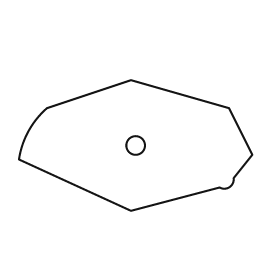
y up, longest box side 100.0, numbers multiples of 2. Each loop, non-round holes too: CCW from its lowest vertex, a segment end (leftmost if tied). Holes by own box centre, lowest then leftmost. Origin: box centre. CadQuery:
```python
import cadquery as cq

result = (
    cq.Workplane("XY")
    .moveTo(-2.0, -28.0)
    .lineTo(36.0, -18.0)
    .threePointArc((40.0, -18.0), (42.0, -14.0))
    .lineTo(50.0, -4.0)
    .lineTo(40.0, 16.0)
    .lineTo(-2.0, 28.0)
    .lineTo(-38.0, 16.0)
    .threePointArc((-46.0, 6.0), (-50.0, -6.0))
    .close()
    .moveTo(0.0, 0.0)
    .circle(4.0)
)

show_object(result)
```